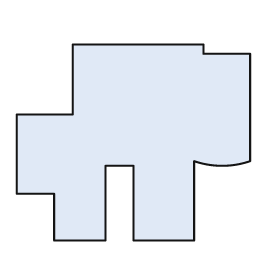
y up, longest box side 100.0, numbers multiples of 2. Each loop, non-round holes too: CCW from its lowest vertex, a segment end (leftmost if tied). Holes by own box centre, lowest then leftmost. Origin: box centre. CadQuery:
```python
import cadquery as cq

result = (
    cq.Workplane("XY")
    .moveTo(-34.0, -42.0)
    .lineTo(-12.0, -42.0)
    .lineTo(-12.0, -10.0)
    .lineTo(0.0, -10.0)
    .lineTo(0.0, -42.0)
    .lineTo(26.0, -42.0)
    .lineTo(26.0, -8.0)
    .threePointArc((38.0, -10.0), (50.0, -8.0))
    .lineTo(50.0, 38.0)
    .lineTo(30.0, 38.0)
    .lineTo(30.0, 42.0)
    .lineTo(-26.0, 42.0)
    .lineTo(-26.0, 12.0)
    .lineTo(-50.0, 12.0)
    .lineTo(-50.0, -22.0)
    .lineTo(-34.0, -22.0)
    .close()
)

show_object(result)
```